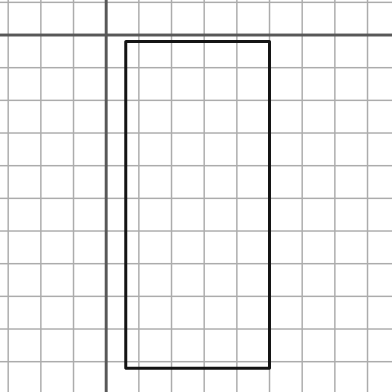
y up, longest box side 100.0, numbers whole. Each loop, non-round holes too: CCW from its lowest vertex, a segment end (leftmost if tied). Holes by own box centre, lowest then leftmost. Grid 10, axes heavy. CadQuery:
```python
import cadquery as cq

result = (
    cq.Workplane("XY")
    .moveTo(6.0, -102.0)
    .lineTo(50.0, -102.0)
    .lineTo(50.0, -2.0)
    .lineTo(6.0, -2.0)
    .close()
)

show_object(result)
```